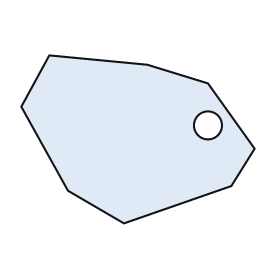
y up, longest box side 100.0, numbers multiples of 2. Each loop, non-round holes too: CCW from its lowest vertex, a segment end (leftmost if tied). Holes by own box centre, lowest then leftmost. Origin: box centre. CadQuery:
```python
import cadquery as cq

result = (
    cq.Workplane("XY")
    .moveTo(-6.0, -36.0)
    .lineTo(40.0, -20.0)
    .lineTo(50.0, -4.0)
    .lineTo(30.0, 24.0)
    .lineTo(4.0, 32.0)
    .lineTo(-38.0, 36.0)
    .lineTo(-50.0, 14.0)
    .lineTo(-30.0, -22.0)
    .close()
    .moveTo(30.0, 6.0)
    .circle(6.0)
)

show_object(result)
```